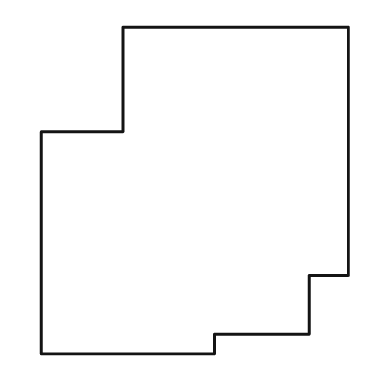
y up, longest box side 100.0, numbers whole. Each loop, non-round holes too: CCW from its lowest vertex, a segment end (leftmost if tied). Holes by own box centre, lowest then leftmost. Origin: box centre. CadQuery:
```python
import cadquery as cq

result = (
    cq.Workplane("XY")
    .moveTo(-47.0, -50.0)
    .lineTo(6.0, -50.0)
    .lineTo(6.0, -44.0)
    .lineTo(35.0, -44.0)
    .lineTo(35.0, -26.0)
    .lineTo(47.0, -26.0)
    .lineTo(47.0, 50.0)
    .lineTo(-22.0, 50.0)
    .lineTo(-22.0, 18.0)
    .lineTo(-47.0, 18.0)
    .close()
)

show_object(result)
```